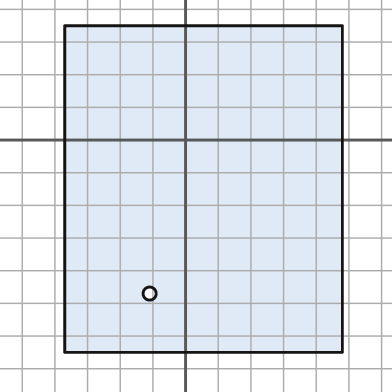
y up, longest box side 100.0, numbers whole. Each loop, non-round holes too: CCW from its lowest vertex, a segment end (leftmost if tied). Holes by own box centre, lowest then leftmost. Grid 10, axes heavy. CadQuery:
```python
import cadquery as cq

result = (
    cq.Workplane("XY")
    .moveTo(-37.0, -65.0)
    .lineTo(48.0, -65.0)
    .lineTo(48.0, 35.0)
    .lineTo(-37.0, 35.0)
    .close()
    .moveTo(-11.0, -47.0)
    .circle(2.0)
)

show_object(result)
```